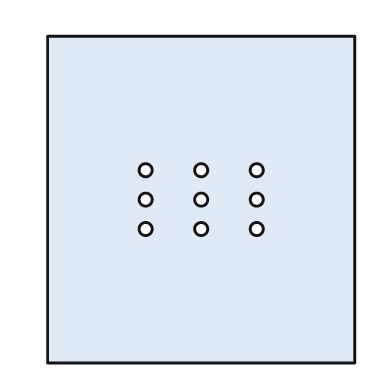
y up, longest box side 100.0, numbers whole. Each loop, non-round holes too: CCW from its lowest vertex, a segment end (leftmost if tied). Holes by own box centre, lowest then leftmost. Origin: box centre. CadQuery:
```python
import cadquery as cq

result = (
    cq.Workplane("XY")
    .moveTo(-47.0, -50.0)
    .lineTo(47.0, -50.0)
    .lineTo(47.0, 50.0)
    .lineTo(-47.0, 50.0)
    .close()
    .moveTo(-17.0, -9.0)
    .circle(2.0)
    .moveTo(0.0, -9.0)
    .circle(2.0)
    .moveTo(17.0, -9.0)
    .circle(2.0)
    .moveTo(-17.0, 0.0)
    .circle(2.0)
    .moveTo(0.0, 0.0)
    .circle(2.0)
    .moveTo(17.0, 0.0)
    .circle(2.0)
    .moveTo(-17.0, 9.0)
    .circle(2.0)
    .moveTo(0.0, 9.0)
    .circle(2.0)
    .moveTo(17.0, 9.0)
    .circle(2.0)
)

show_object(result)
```